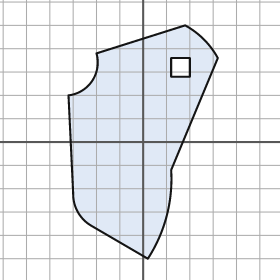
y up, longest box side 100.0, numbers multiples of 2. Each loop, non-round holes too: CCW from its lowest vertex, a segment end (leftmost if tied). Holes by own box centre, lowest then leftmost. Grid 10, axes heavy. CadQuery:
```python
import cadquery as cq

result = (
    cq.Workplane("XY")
    .moveTo(2.0, -50.0)
    .threePointArc((10.0, -32.0), (12.0, -12.0))
    .lineTo(32.0, 36.0)
    .threePointArc((26.0, 44.0), (18.0, 50.0))
    .lineTo(-20.0, 38.0)
    .threePointArc((-22.0, 26.0), (-32.0, 20.0))
    .lineTo(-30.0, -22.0)
    .threePointArc((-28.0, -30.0), (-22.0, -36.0))
    .close()
    .moveTo(12.0, 28.0)
    .lineTo(20.0, 28.0)
    .lineTo(20.0, 36.0)
    .lineTo(12.0, 36.0)
    .close()
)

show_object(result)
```